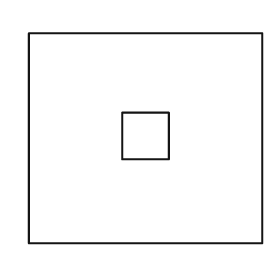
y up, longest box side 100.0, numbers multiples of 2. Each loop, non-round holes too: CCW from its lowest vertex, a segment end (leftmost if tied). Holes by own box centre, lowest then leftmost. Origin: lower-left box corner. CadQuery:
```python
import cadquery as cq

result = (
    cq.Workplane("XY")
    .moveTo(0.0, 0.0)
    .lineTo(100.0, 0.0)
    .lineTo(100.0, 90.0)
    .lineTo(0.0, 90.0)
    .close()
    .moveTo(40.0, 36.0)
    .lineTo(60.0, 36.0)
    .lineTo(60.0, 56.0)
    .lineTo(40.0, 56.0)
    .close()
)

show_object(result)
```